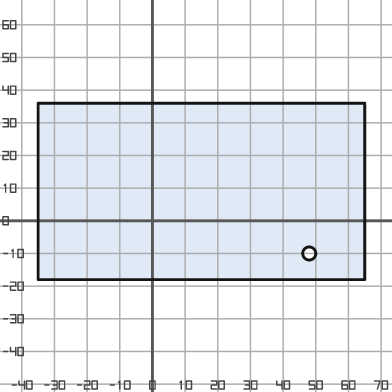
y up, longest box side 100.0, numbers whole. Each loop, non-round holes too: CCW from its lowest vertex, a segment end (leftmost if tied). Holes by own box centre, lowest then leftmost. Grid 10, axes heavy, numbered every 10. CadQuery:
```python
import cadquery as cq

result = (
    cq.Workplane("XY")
    .moveTo(-35.0, -18.0)
    .lineTo(65.0, -18.0)
    .lineTo(65.0, 36.0)
    .lineTo(-35.0, 36.0)
    .close()
    .moveTo(48.0, -10.0)
    .circle(2.0)
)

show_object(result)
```